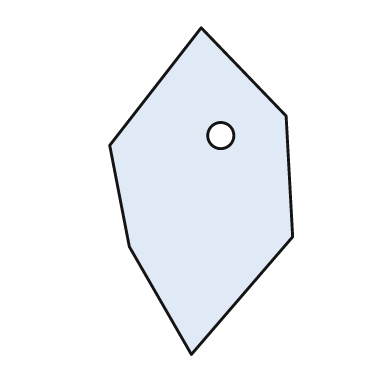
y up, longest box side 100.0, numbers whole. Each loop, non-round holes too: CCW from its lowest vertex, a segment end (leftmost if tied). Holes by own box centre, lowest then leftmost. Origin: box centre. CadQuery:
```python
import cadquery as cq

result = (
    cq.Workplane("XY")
    .moveTo(-3.0, -50.0)
    .lineTo(28.0, -14.0)
    .lineTo(26.0, 23.0)
    .lineTo(0.0, 50.0)
    .lineTo(-28.0, 14.0)
    .lineTo(-22.0, -17.0)
    .close()
    .moveTo(6.0, 17.0)
    .circle(4.0)
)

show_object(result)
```